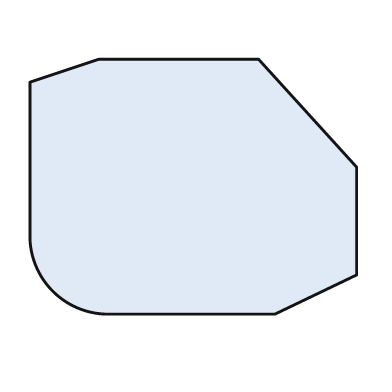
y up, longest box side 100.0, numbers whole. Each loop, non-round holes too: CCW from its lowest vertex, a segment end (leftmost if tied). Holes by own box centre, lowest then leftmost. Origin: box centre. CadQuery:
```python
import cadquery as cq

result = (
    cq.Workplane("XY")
    .moveTo(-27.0, -39.0)
    .lineTo(25.0, -39.0)
    .lineTo(50.0, -27.0)
    .lineTo(50.0, 6.0)
    .lineTo(20.0, 39.0)
    .lineTo(-29.0, 39.0)
    .lineTo(-50.0, 32.0)
    .lineTo(-50.0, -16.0)
    .threePointArc((-43.0, -32.0), (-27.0, -39.0))
    .close()
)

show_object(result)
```